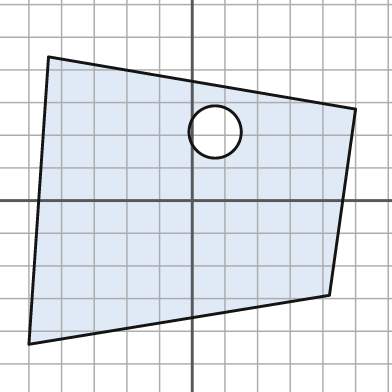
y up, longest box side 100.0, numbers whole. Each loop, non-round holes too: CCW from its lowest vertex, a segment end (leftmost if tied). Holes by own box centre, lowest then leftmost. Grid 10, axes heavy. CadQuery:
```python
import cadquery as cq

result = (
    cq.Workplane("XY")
    .moveTo(-50.0, -44.0)
    .lineTo(42.0, -29.0)
    .lineTo(50.0, 28.0)
    .lineTo(-44.0, 44.0)
    .close()
    .moveTo(7.0, 21.0)
    .circle(8.0)
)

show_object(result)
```